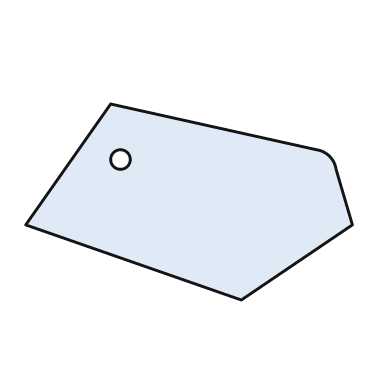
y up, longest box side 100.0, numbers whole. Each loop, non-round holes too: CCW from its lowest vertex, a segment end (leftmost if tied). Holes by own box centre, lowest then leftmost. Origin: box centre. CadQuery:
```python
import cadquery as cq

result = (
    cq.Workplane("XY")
    .moveTo(16.0, -30.0)
    .lineTo(50.0, -7.0)
    .lineTo(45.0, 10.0)
    .threePointArc((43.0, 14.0), (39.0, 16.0))
    .lineTo(-24.0, 30.0)
    .lineTo(-50.0, -7.0)
    .close()
    .moveTo(-21.0, 13.0)
    .circle(3.0)
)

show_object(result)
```